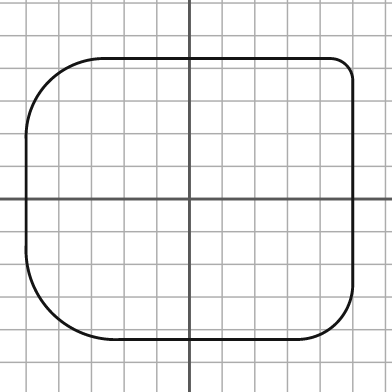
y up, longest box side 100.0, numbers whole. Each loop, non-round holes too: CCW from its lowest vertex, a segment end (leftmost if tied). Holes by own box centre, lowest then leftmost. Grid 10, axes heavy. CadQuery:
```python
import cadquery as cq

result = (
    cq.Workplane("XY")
    .moveTo(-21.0, -43.0)
    .lineTo(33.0, -43.0)
    .threePointArc((45.0, -38.0), (50.0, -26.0))
    .lineTo(50.0, 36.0)
    .threePointArc((48.0, 41.0), (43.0, 43.0))
    .lineTo(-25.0, 43.0)
    .threePointArc((-43.0, 36.0), (-50.0, 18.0))
    .lineTo(-50.0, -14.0)
    .threePointArc((-42.0, -35.0), (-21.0, -43.0))
    .close()
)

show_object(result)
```